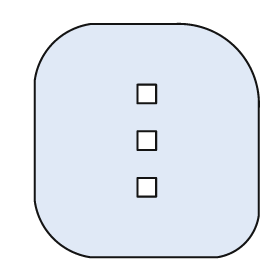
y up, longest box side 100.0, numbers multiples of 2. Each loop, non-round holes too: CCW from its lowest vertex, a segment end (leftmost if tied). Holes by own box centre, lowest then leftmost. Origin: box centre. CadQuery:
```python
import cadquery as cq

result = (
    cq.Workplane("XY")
    .moveTo(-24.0, -50.0)
    .lineTo(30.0, -50.0)
    .threePointArc((42.0, -44.0), (48.0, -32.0))
    .lineTo(48.0, 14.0)
    .threePointArc((38.0, 40.0), (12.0, 50.0))
    .lineTo(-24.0, 50.0)
    .threePointArc((-40.0, 42.0), (-48.0, 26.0))
    .lineTo(-48.0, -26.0)
    .threePointArc((-40.0, -42.0), (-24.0, -50.0))
    .close()
    .moveTo(-4.0, -24.0)
    .lineTo(4.0, -24.0)
    .lineTo(4.0, -16.0)
    .lineTo(-4.0, -16.0)
    .close()
    .moveTo(-4.0, -4.0)
    .lineTo(4.0, -4.0)
    .lineTo(4.0, 4.0)
    .lineTo(-4.0, 4.0)
    .close()
    .moveTo(-4.0, 16.0)
    .lineTo(4.0, 16.0)
    .lineTo(4.0, 24.0)
    .lineTo(-4.0, 24.0)
    .close()
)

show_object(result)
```